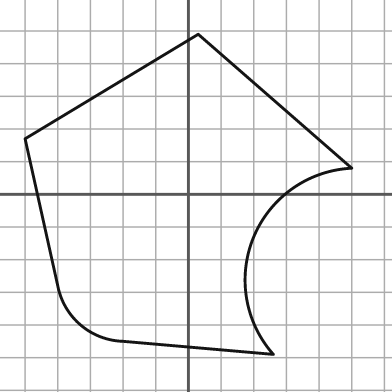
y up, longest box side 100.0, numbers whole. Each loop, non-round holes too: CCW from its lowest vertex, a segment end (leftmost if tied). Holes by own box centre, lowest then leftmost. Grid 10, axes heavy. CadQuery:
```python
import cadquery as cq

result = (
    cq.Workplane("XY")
    .moveTo(26.0, -49.0)
    .threePointArc((20.0, -13.0), (50.0, 8.0))
    .lineTo(3.0, 49.0)
    .lineTo(-50.0, 17.0)
    .lineTo(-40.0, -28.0)
    .threePointArc((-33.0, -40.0), (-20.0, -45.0))
    .close()
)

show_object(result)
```